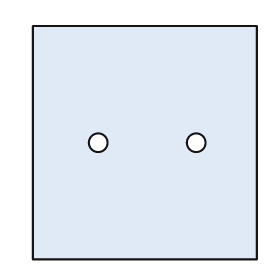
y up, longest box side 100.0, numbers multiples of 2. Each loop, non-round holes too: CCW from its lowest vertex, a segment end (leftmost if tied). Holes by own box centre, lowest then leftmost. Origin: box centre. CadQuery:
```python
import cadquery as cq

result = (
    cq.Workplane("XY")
    .moveTo(-48.0, -50.0)
    .lineTo(48.0, -50.0)
    .lineTo(48.0, 50.0)
    .lineTo(-48.0, 50.0)
    .close()
    .moveTo(-20.0, 0.0)
    .circle(4.0)
    .moveTo(22.0, 0.0)
    .circle(4.0)
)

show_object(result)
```